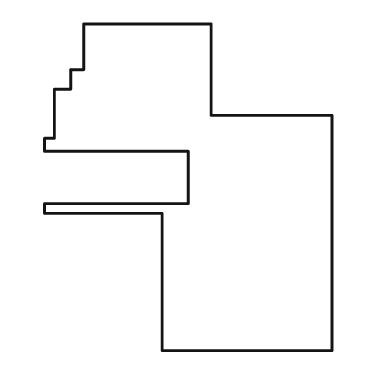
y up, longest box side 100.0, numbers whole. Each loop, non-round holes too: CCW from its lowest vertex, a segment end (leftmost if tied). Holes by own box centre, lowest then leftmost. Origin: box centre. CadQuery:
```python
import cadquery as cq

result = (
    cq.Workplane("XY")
    .moveTo(-8.0, -50.0)
    .lineTo(44.0, -50.0)
    .lineTo(44.0, 22.0)
    .lineTo(7.0, 22.0)
    .lineTo(7.0, 50.0)
    .lineTo(-32.0, 50.0)
    .lineTo(-32.0, 36.0)
    .lineTo(-36.0, 36.0)
    .lineTo(-36.0, 30.0)
    .lineTo(-41.0, 30.0)
    .lineTo(-41.0, 15.0)
    .lineTo(-44.0, 15.0)
    .lineTo(-44.0, 11.0)
    .lineTo(0.0, 11.0)
    .lineTo(0.0, -5.0)
    .lineTo(-44.0, -5.0)
    .lineTo(-44.0, -8.0)
    .lineTo(-8.0, -8.0)
    .close()
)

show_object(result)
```